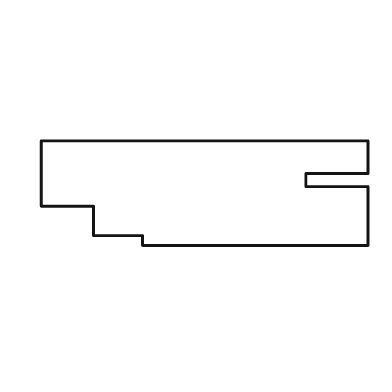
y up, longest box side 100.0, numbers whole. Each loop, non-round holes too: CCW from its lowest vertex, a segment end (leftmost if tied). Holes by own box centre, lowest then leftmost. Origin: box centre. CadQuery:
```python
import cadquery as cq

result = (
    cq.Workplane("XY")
    .moveTo(-19.0, -16.0)
    .lineTo(50.0, -16.0)
    .lineTo(50.0, 2.0)
    .lineTo(31.0, 2.0)
    .lineTo(31.0, 6.0)
    .lineTo(50.0, 6.0)
    .lineTo(50.0, 16.0)
    .lineTo(-50.0, 16.0)
    .lineTo(-50.0, -4.0)
    .lineTo(-34.0, -4.0)
    .lineTo(-34.0, -13.0)
    .lineTo(-19.0, -13.0)
    .close()
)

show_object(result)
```